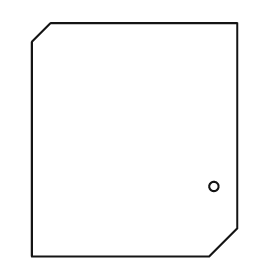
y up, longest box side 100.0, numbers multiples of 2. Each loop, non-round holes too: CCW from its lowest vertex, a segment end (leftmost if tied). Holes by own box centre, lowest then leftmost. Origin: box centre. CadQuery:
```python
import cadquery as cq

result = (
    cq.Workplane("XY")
    .moveTo(-44.0, -50.0)
    .lineTo(32.0, -50.0)
    .lineTo(44.0, -38.0)
    .lineTo(44.0, 50.0)
    .lineTo(-36.0, 50.0)
    .lineTo(-44.0, 42.0)
    .close()
    .moveTo(34.0, -20.0)
    .circle(2.0)
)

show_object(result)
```